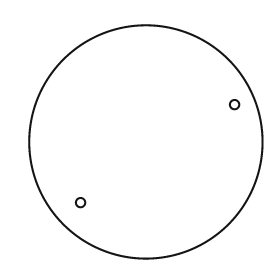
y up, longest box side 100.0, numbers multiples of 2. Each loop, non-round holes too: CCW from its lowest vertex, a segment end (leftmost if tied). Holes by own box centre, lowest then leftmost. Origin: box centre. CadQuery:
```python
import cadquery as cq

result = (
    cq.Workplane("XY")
    .moveTo(0.0, 0.0)
    .circle(50.0)
    .moveTo(-28.0, -26.0)
    .circle(2.0)
    .moveTo(38.0, 16.0)
    .circle(2.0)
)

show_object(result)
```